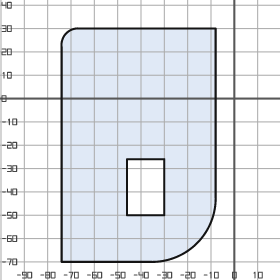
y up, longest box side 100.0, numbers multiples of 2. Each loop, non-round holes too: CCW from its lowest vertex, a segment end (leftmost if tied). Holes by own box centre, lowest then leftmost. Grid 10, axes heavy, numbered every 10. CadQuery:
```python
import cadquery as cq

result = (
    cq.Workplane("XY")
    .moveTo(-74.0, -70.0)
    .lineTo(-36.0, -70.0)
    .threePointArc((-16.0, -62.0), (-8.0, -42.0))
    .lineTo(-8.0, 30.0)
    .lineTo(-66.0, 30.0)
    .threePointArc((-72.0, 28.0), (-74.0, 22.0))
    .close()
    .moveTo(-46.0, -50.0)
    .lineTo(-30.0, -50.0)
    .lineTo(-30.0, -26.0)
    .lineTo(-46.0, -26.0)
    .close()
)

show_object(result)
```